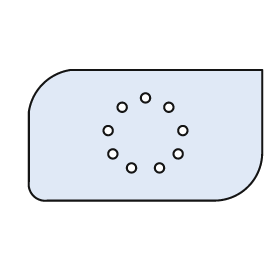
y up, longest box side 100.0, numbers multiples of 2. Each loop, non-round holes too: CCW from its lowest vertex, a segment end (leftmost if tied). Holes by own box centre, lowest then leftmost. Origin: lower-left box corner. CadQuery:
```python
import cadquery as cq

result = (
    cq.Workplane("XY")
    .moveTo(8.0, 0.0)
    .lineTo(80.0, 0.0)
    .threePointArc((94.0, 6.0), (100.0, 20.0))
    .lineTo(100.0, 56.0)
    .lineTo(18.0, 56.0)
    .threePointArc((6.0, 50.0), (0.0, 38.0))
    .lineTo(0.0, 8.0)
    .threePointArc((2.0, 2.0), (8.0, 0.0))
    .close()
    .moveTo(44.0, 14.0)
    .circle(2.0)
    .moveTo(56.0, 14.0)
    .circle(2.0)
    .moveTo(36.0, 20.0)
    .circle(2.0)
    .moveTo(64.0, 20.0)
    .circle(2.0)
    .moveTo(34.0, 30.0)
    .circle(2.0)
    .moveTo(66.0, 30.0)
    .circle(2.0)
    .moveTo(40.0, 40.0)
    .circle(2.0)
    .moveTo(60.0, 40.0)
    .circle(2.0)
    .moveTo(50.0, 44.0)
    .circle(2.0)
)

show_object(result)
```